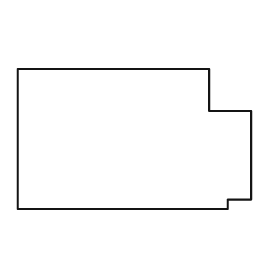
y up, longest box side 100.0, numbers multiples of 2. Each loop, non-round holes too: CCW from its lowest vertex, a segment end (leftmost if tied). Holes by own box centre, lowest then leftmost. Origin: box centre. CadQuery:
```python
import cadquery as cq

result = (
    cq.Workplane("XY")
    .moveTo(-50.0, -30.0)
    .lineTo(40.0, -30.0)
    .lineTo(40.0, -26.0)
    .lineTo(50.0, -26.0)
    .lineTo(50.0, 12.0)
    .lineTo(32.0, 12.0)
    .lineTo(32.0, 30.0)
    .lineTo(-50.0, 30.0)
    .close()
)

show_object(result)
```